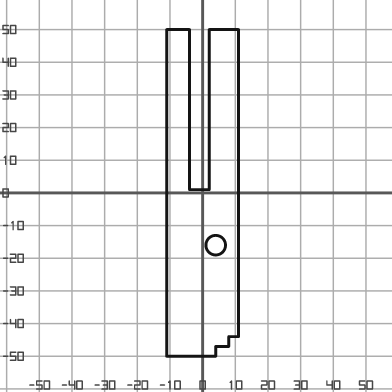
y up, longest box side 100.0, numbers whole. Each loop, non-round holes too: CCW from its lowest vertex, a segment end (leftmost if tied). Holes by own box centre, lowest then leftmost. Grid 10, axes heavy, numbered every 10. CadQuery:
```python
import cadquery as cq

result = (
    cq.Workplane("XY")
    .moveTo(-11.0, -50.0)
    .lineTo(4.0, -50.0)
    .lineTo(4.0, -47.0)
    .lineTo(8.0, -47.0)
    .lineTo(8.0, -44.0)
    .lineTo(11.0, -44.0)
    .lineTo(11.0, 50.0)
    .lineTo(2.0, 50.0)
    .lineTo(2.0, 1.0)
    .lineTo(-4.0, 1.0)
    .lineTo(-4.0, 50.0)
    .lineTo(-11.0, 50.0)
    .close()
    .moveTo(4.0, -16.0)
    .circle(3.0)
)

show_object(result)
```